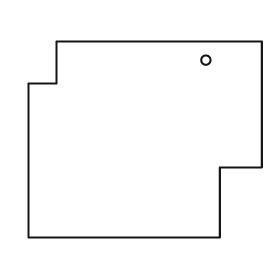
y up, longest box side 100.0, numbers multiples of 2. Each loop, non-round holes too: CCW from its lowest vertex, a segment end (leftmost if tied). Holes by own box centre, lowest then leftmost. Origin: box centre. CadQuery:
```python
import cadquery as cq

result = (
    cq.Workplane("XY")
    .moveTo(-50.0, -42.0)
    .lineTo(32.0, -42.0)
    .lineTo(32.0, -12.0)
    .lineTo(50.0, -12.0)
    .lineTo(50.0, 42.0)
    .lineTo(-38.0, 42.0)
    .lineTo(-38.0, 24.0)
    .lineTo(-50.0, 24.0)
    .close()
    .moveTo(26.0, 34.0)
    .circle(2.0)
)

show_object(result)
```